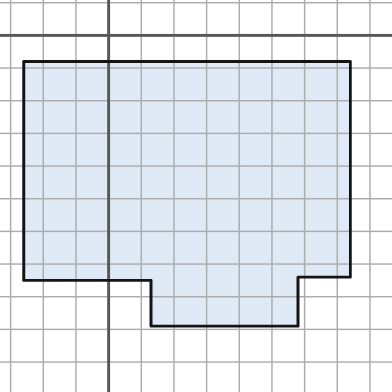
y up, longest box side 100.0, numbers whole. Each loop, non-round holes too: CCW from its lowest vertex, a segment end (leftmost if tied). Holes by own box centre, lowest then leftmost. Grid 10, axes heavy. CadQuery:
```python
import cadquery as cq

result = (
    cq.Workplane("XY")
    .moveTo(13.0, -89.0)
    .lineTo(58.0, -89.0)
    .lineTo(58.0, -74.0)
    .lineTo(74.0, -74.0)
    .lineTo(74.0, -8.0)
    .lineTo(-26.0, -8.0)
    .lineTo(-26.0, -75.0)
    .lineTo(13.0, -75.0)
    .close()
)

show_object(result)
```